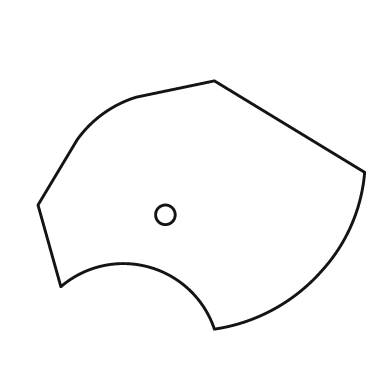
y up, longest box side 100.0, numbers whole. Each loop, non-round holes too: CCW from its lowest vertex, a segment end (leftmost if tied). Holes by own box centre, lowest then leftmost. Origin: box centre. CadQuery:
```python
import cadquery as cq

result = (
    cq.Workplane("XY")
    .moveTo(4.0, -38.0)
    .threePointArc((22.0, -32.0), (37.0, -20.0))
    .threePointArc((46.0, -6.0), (50.0, 10.0))
    .lineTo(4.0, 38.0)
    .lineTo(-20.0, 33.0)
    .threePointArc((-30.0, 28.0), (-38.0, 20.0))
    .lineTo(-50.0, 0.0)
    .lineTo(-43.0, -25.0)
    .threePointArc((-16.0, -19.0), (4.0, -38.0))
    .close()
    .moveTo(-11.0, -3.0)
    .circle(3.0)
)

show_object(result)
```